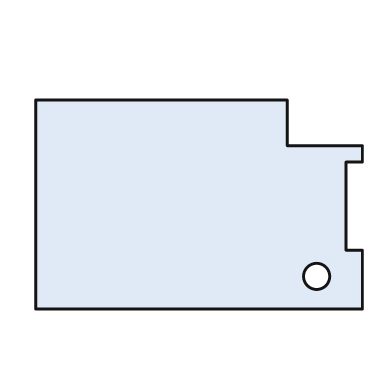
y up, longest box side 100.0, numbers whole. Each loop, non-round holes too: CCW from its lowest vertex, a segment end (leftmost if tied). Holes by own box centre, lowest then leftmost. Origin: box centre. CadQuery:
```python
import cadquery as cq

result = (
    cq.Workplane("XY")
    .moveTo(-50.0, -32.0)
    .lineTo(50.0, -32.0)
    .lineTo(50.0, -14.0)
    .lineTo(45.0, -14.0)
    .lineTo(45.0, 13.0)
    .lineTo(50.0, 13.0)
    .lineTo(50.0, 18.0)
    .lineTo(27.0, 18.0)
    .lineTo(27.0, 32.0)
    .lineTo(-50.0, 32.0)
    .close()
    .moveTo(36.0, -22.0)
    .circle(4.0)
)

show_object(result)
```